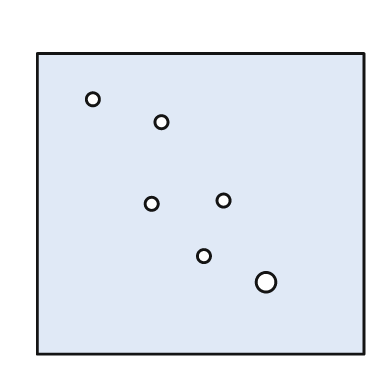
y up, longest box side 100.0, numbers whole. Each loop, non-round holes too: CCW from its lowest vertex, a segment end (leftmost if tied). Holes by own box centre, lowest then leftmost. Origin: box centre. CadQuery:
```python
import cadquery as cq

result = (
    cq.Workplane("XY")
    .moveTo(-50.0, -46.0)
    .lineTo(50.0, -46.0)
    .lineTo(50.0, 46.0)
    .lineTo(-50.0, 46.0)
    .close()
    .moveTo(20.0, -24.0)
    .circle(3.0)
    .moveTo(1.0, -16.0)
    .circle(2.0)
    .moveTo(-15.0, 0.0)
    .circle(2.0)
    .moveTo(7.0, 1.0)
    .circle(2.0)
    .moveTo(-12.0, 25.0)
    .circle(2.0)
    .moveTo(-33.0, 32.0)
    .circle(2.0)
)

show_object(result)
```